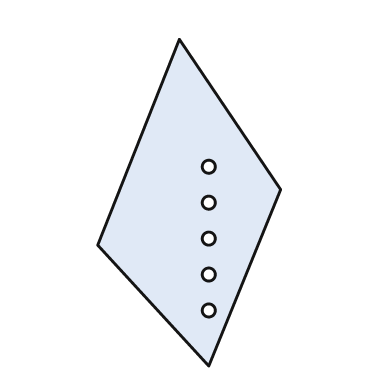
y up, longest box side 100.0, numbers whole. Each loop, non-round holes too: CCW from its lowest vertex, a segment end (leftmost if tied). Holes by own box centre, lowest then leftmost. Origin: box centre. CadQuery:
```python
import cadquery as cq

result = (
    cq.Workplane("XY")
    .moveTo(6.0, -50.0)
    .lineTo(28.0, 4.0)
    .lineTo(-3.0, 50.0)
    .lineTo(-28.0, -13.0)
    .close()
    .moveTo(6.0, -33.0)
    .circle(2.0)
    .moveTo(6.0, -22.0)
    .circle(2.0)
    .moveTo(6.0, -11.0)
    .circle(2.0)
    .moveTo(6.0, 0.0)
    .circle(2.0)
    .moveTo(6.0, 11.0)
    .circle(2.0)
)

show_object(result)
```